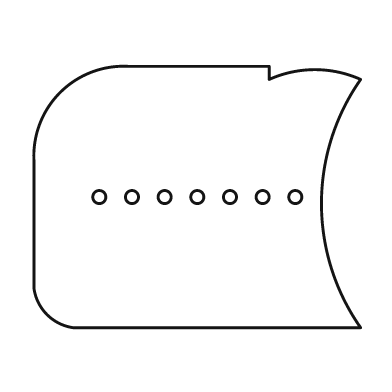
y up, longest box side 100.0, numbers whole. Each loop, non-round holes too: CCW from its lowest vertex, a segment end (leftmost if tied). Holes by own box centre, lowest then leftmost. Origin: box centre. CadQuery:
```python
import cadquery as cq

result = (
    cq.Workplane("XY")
    .moveTo(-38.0, -40.0)
    .lineTo(50.0, -40.0)
    .threePointArc((38.0, -2.0), (50.0, 36.0))
    .threePointArc((36.0, 39.0), (22.0, 36.0))
    .lineTo(22.0, 40.0)
    .lineTo(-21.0, 40.0)
    .threePointArc((-42.0, 32.0), (-50.0, 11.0))
    .lineTo(-50.0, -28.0)
    .threePointArc((-46.0, -36.0), (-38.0, -40.0))
    .close()
    .moveTo(-30.0, 0.0)
    .circle(2.0)
    .moveTo(-20.0, 0.0)
    .circle(2.0)
    .moveTo(-10.0, 0.0)
    .circle(2.0)
    .moveTo(0.0, 0.0)
    .circle(2.0)
    .moveTo(10.0, 0.0)
    .circle(2.0)
    .moveTo(20.0, 0.0)
    .circle(2.0)
    .moveTo(30.0, 0.0)
    .circle(2.0)
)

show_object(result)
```